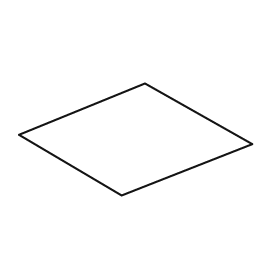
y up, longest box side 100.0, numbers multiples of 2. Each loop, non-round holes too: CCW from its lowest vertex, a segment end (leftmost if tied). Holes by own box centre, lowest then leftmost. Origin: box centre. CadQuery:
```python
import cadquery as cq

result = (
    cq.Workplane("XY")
    .moveTo(-6.0, -24.0)
    .lineTo(50.0, -2.0)
    .lineTo(4.0, 24.0)
    .lineTo(-50.0, 2.0)
    .close()
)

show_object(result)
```